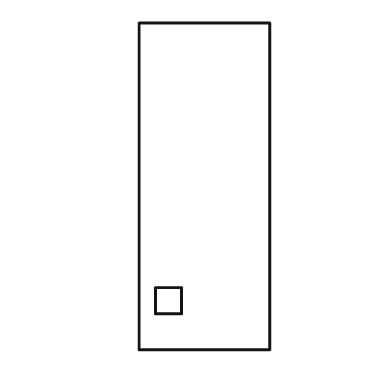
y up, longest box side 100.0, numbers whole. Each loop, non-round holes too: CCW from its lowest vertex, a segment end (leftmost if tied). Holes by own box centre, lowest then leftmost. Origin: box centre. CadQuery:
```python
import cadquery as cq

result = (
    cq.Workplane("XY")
    .moveTo(-20.0, -50.0)
    .lineTo(20.0, -50.0)
    .lineTo(20.0, 50.0)
    .lineTo(-20.0, 50.0)
    .close()
    .moveTo(-15.0, -39.0)
    .lineTo(-7.0, -39.0)
    .lineTo(-7.0, -31.0)
    .lineTo(-15.0, -31.0)
    .close()
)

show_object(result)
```